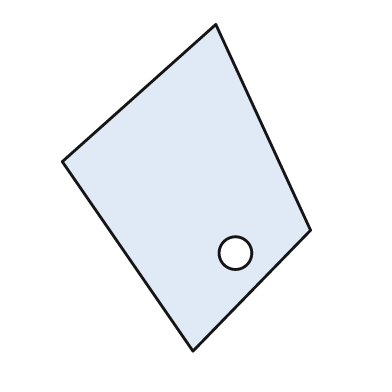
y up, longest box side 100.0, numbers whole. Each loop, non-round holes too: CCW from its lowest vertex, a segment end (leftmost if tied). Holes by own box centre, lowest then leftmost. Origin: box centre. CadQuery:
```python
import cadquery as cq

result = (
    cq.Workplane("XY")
    .moveTo(2.0, -50.0)
    .lineTo(38.0, -13.0)
    .lineTo(9.0, 50.0)
    .lineTo(-38.0, 8.0)
    .close()
    .moveTo(15.0, -20.0)
    .circle(5.0)
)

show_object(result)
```